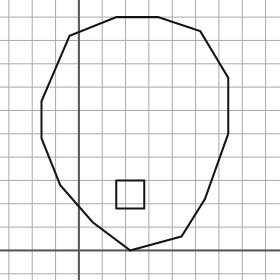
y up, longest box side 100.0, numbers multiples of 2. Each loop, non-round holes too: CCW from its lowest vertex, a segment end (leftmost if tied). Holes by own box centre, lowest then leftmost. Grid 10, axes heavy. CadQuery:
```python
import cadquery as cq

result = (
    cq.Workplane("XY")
    .moveTo(22.0, 0.0)
    .lineTo(44.0, 6.0)
    .lineTo(54.0, 22.0)
    .lineTo(64.0, 50.0)
    .lineTo(64.0, 74.0)
    .lineTo(52.0, 94.0)
    .lineTo(34.0, 100.0)
    .lineTo(16.0, 100.0)
    .lineTo(-4.0, 92.0)
    .lineTo(-16.0, 64.0)
    .lineTo(-16.0, 48.0)
    .lineTo(-8.0, 28.0)
    .lineTo(6.0, 12.0)
    .close()
    .moveTo(16.0, 18.0)
    .lineTo(28.0, 18.0)
    .lineTo(28.0, 30.0)
    .lineTo(16.0, 30.0)
    .close()
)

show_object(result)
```